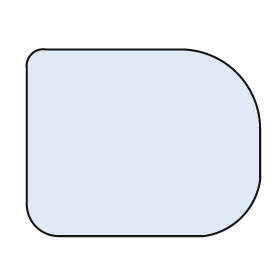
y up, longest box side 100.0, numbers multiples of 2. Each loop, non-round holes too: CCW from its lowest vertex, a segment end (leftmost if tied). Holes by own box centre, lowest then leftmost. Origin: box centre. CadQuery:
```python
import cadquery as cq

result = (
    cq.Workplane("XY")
    .moveTo(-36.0, -40.0)
    .lineTo(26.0, -40.0)
    .threePointArc((42.0, -32.0), (50.0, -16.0))
    .lineTo(50.0, 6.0)
    .threePointArc((40.0, 30.0), (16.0, 40.0))
    .lineTo(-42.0, 40.0)
    .threePointArc((-48.0, 38.0), (-50.0, 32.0))
    .lineTo(-50.0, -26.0)
    .threePointArc((-46.0, -36.0), (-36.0, -40.0))
    .close()
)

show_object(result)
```